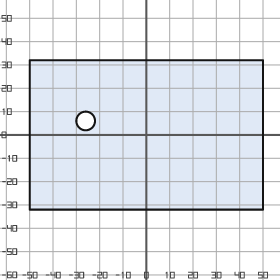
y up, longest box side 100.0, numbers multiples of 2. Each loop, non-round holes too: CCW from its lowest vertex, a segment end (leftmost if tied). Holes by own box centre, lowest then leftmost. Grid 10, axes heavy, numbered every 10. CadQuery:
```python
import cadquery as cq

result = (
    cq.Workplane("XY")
    .moveTo(-50.0, -32.0)
    .lineTo(50.0, -32.0)
    .lineTo(50.0, 32.0)
    .lineTo(-50.0, 32.0)
    .close()
    .moveTo(-26.0, 6.0)
    .circle(4.0)
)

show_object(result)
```